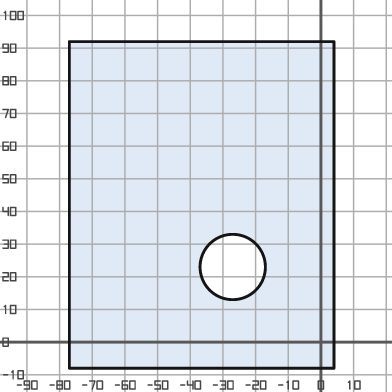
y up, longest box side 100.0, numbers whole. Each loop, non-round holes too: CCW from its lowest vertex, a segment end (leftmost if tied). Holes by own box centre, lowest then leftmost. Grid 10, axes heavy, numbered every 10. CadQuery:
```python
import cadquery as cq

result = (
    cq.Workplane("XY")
    .moveTo(-77.0, -8.0)
    .lineTo(4.0, -8.0)
    .lineTo(4.0, 92.0)
    .lineTo(-77.0, 92.0)
    .close()
    .moveTo(-27.0, 23.0)
    .circle(10.0)
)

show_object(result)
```